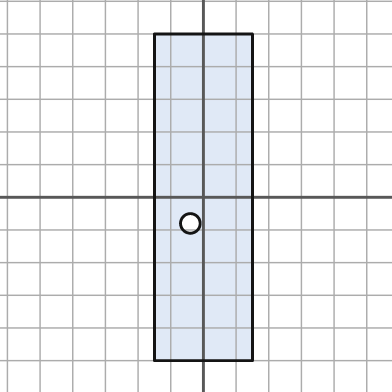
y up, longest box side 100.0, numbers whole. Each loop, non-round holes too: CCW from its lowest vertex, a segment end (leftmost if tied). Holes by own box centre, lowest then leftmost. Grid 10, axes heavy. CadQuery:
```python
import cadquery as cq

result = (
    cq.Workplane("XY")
    .moveTo(-15.0, -50.0)
    .lineTo(15.0, -50.0)
    .lineTo(15.0, 50.0)
    .lineTo(-15.0, 50.0)
    .close()
    .moveTo(-4.0, -8.0)
    .circle(3.0)
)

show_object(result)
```